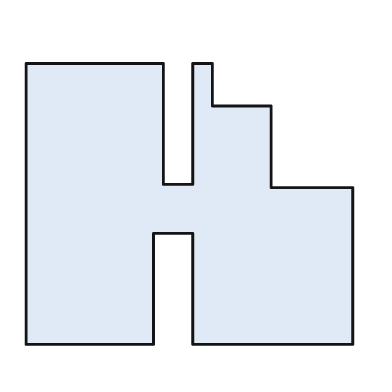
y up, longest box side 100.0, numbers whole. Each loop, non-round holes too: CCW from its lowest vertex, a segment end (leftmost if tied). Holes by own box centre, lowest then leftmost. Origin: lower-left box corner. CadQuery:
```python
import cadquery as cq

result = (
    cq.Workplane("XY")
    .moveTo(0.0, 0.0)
    .lineTo(39.0, 0.0)
    .lineTo(39.0, 34.0)
    .lineTo(51.0, 34.0)
    .lineTo(51.0, 0.0)
    .lineTo(100.0, 0.0)
    .lineTo(100.0, 48.0)
    .lineTo(75.0, 48.0)
    .lineTo(75.0, 73.0)
    .lineTo(57.0, 73.0)
    .lineTo(57.0, 86.0)
    .lineTo(51.0, 86.0)
    .lineTo(51.0, 49.0)
    .lineTo(42.0, 49.0)
    .lineTo(42.0, 86.0)
    .lineTo(0.0, 86.0)
    .close()
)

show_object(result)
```